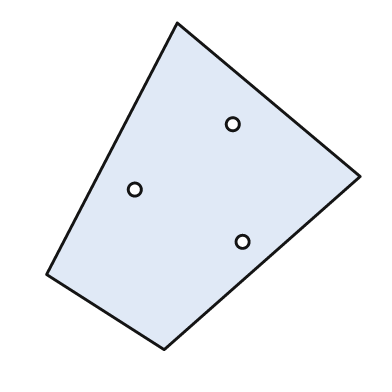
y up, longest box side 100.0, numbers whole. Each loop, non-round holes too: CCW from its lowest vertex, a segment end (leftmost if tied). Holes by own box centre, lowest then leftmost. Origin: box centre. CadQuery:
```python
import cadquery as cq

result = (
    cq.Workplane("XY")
    .moveTo(-12.0, -50.0)
    .lineTo(48.0, 3.0)
    .lineTo(-8.0, 50.0)
    .lineTo(-48.0, -27.0)
    .close()
    .moveTo(12.0, -17.0)
    .circle(2.0)
    .moveTo(-21.0, -1.0)
    .circle(2.0)
    .moveTo(9.0, 19.0)
    .circle(2.0)
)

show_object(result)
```